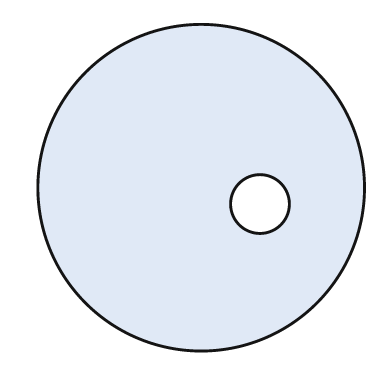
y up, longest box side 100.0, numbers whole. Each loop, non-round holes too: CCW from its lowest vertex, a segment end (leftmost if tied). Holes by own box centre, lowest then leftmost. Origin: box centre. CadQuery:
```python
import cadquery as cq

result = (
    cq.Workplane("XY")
    .moveTo(0.0, 0.0)
    .circle(50.0)
    .moveTo(18.0, -5.0)
    .circle(9.0)
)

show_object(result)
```